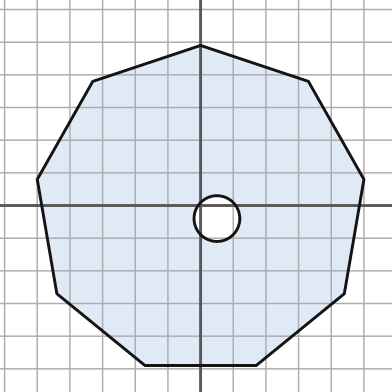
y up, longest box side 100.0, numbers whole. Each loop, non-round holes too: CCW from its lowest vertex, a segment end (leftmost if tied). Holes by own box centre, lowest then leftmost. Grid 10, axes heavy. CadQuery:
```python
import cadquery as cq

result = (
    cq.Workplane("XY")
    .moveTo(-17.0, -49.0)
    .lineTo(17.0, -49.0)
    .lineTo(44.0, -27.0)
    .lineTo(50.0, 8.0)
    .lineTo(33.0, 38.0)
    .lineTo(0.0, 49.0)
    .lineTo(-33.0, 38.0)
    .lineTo(-50.0, 8.0)
    .lineTo(-44.0, -27.0)
    .close()
    .moveTo(5.0, -4.0)
    .circle(7.0)
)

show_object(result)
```